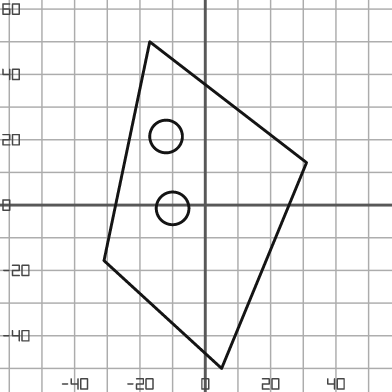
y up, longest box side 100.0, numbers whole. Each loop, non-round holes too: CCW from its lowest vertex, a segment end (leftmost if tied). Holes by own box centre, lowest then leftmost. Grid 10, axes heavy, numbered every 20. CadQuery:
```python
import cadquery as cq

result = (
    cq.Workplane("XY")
    .moveTo(5.0, -50.0)
    .lineTo(31.0, 13.0)
    .lineTo(-17.0, 50.0)
    .lineTo(-31.0, -17.0)
    .close()
    .moveTo(-10.0, -1.0)
    .circle(5.0)
    .moveTo(-12.0, 21.0)
    .circle(5.0)
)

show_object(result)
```